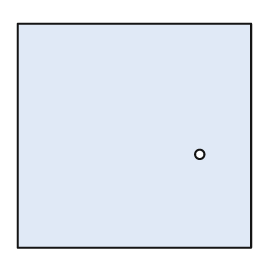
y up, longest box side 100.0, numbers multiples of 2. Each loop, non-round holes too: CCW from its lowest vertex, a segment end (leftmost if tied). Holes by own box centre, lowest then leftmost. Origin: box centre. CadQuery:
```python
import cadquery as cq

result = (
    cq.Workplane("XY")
    .moveTo(-50.0, -48.0)
    .lineTo(50.0, -48.0)
    .lineTo(50.0, 48.0)
    .lineTo(-50.0, 48.0)
    .close()
    .moveTo(28.0, -8.0)
    .circle(2.0)
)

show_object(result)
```